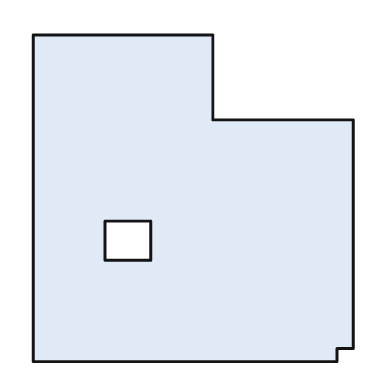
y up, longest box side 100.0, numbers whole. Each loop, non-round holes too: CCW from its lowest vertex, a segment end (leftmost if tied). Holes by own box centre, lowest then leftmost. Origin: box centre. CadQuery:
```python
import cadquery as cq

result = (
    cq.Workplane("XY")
    .moveTo(-49.0, -50.0)
    .lineTo(44.0, -50.0)
    .lineTo(44.0, -46.0)
    .lineTo(49.0, -46.0)
    .lineTo(49.0, 24.0)
    .lineTo(6.0, 24.0)
    .lineTo(6.0, 50.0)
    .lineTo(-49.0, 50.0)
    .close()
    .moveTo(-27.0, -19.0)
    .lineTo(-13.0, -19.0)
    .lineTo(-13.0, -7.0)
    .lineTo(-27.0, -7.0)
    .close()
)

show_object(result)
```